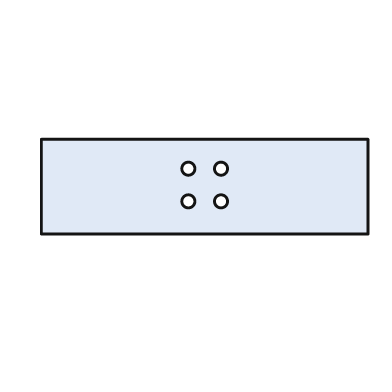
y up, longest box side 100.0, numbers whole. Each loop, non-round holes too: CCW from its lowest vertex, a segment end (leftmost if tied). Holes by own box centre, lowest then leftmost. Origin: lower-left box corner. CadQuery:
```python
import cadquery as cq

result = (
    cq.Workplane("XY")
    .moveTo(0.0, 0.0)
    .lineTo(100.0, 0.0)
    .lineTo(100.0, 29.0)
    .lineTo(0.0, 29.0)
    .close()
    .moveTo(45.0, 10.0)
    .circle(2.0)
    .moveTo(55.0, 10.0)
    .circle(2.0)
    .moveTo(45.0, 20.0)
    .circle(2.0)
    .moveTo(55.0, 20.0)
    .circle(2.0)
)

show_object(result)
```